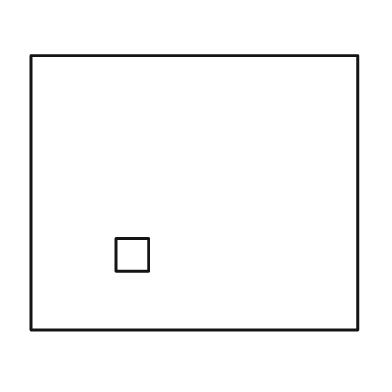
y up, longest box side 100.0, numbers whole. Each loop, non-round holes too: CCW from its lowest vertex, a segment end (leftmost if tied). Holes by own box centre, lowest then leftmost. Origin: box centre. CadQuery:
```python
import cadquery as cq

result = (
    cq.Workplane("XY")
    .moveTo(-50.0, -42.0)
    .lineTo(50.0, -42.0)
    .lineTo(50.0, 42.0)
    .lineTo(-50.0, 42.0)
    .close()
    .moveTo(-24.0, -24.0)
    .lineTo(-14.0, -24.0)
    .lineTo(-14.0, -14.0)
    .lineTo(-24.0, -14.0)
    .close()
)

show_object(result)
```